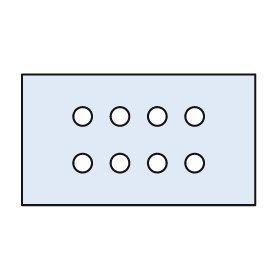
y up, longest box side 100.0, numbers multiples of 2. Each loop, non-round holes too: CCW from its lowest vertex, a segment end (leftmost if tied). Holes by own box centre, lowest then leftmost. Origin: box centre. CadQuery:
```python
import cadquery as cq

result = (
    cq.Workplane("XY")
    .moveTo(-50.0, -28.0)
    .lineTo(50.0, -28.0)
    .lineTo(50.0, 28.0)
    .lineTo(-50.0, 28.0)
    .close()
    .moveTo(-24.0, -10.0)
    .circle(4.0)
    .moveTo(-8.0, -10.0)
    .circle(4.0)
    .moveTo(8.0, -10.0)
    .circle(4.0)
    .moveTo(24.0, -10.0)
    .circle(4.0)
    .moveTo(-24.0, 10.0)
    .circle(4.0)
    .moveTo(-8.0, 10.0)
    .circle(4.0)
    .moveTo(8.0, 10.0)
    .circle(4.0)
    .moveTo(24.0, 10.0)
    .circle(4.0)
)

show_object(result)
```